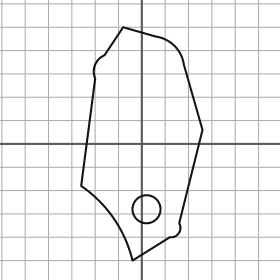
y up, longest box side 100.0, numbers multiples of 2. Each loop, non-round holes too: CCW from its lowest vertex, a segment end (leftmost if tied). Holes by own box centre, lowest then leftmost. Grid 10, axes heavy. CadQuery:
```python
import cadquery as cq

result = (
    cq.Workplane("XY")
    .moveTo(-4.0, -50.0)
    .lineTo(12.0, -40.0)
    .threePointArc((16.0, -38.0), (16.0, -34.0))
    .lineTo(26.0, 6.0)
    .lineTo(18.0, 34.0)
    .threePointArc((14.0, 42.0), (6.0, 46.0))
    .lineTo(-8.0, 50.0)
    .lineTo(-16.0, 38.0)
    .threePointArc((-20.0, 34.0), (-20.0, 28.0))
    .lineTo(-26.0, -18.0)
    .threePointArc((-12.0, -32.0), (-4.0, -50.0))
    .close()
    .moveTo(2.0, -28.0)
    .circle(6.0)
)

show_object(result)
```